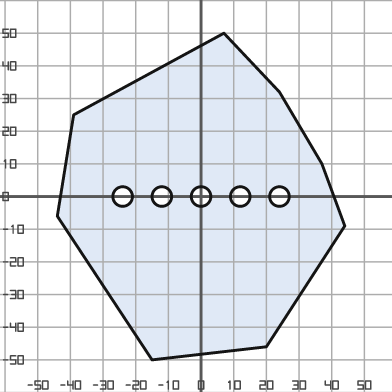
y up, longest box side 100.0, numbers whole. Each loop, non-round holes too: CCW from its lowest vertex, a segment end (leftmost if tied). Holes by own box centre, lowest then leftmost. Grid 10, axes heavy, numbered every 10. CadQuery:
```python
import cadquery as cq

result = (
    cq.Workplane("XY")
    .moveTo(-15.0, -50.0)
    .lineTo(20.0, -46.0)
    .lineTo(44.0, -9.0)
    .lineTo(37.0, 10.0)
    .lineTo(24.0, 32.0)
    .lineTo(7.0, 50.0)
    .lineTo(-39.0, 25.0)
    .lineTo(-44.0, -6.0)
    .close()
    .moveTo(-24.0, 0.0)
    .circle(3.0)
    .moveTo(-12.0, 0.0)
    .circle(3.0)
    .moveTo(0.0, 0.0)
    .circle(3.0)
    .moveTo(12.0, 0.0)
    .circle(3.0)
    .moveTo(24.0, 0.0)
    .circle(3.0)
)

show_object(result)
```